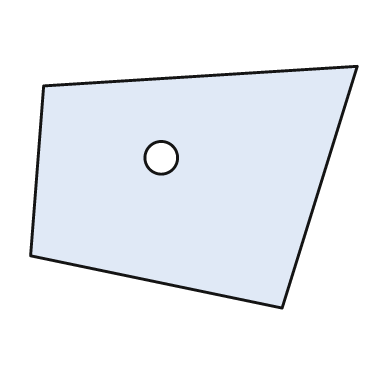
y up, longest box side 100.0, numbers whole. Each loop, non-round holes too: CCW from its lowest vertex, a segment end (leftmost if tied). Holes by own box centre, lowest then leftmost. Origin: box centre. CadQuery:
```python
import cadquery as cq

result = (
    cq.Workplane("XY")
    .moveTo(27.0, -37.0)
    .lineTo(50.0, 37.0)
    .lineTo(-46.0, 31.0)
    .lineTo(-50.0, -21.0)
    .close()
    .moveTo(-10.0, 9.0)
    .circle(5.0)
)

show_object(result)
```